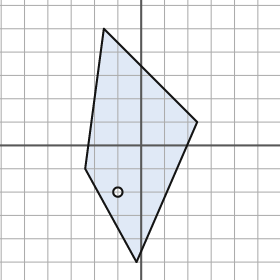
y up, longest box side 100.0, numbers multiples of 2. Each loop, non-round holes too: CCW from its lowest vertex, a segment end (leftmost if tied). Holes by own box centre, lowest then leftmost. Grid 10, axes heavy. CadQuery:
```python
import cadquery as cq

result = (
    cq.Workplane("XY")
    .moveTo(-2.0, -50.0)
    .lineTo(24.0, 10.0)
    .lineTo(-16.0, 50.0)
    .lineTo(-24.0, -10.0)
    .close()
    .moveTo(-10.0, -20.0)
    .circle(2.0)
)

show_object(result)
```